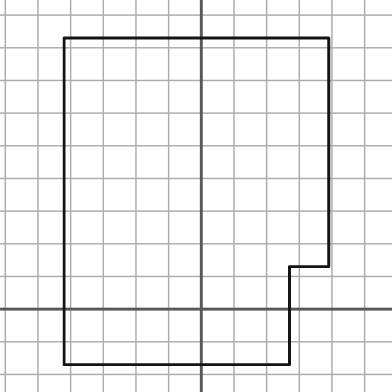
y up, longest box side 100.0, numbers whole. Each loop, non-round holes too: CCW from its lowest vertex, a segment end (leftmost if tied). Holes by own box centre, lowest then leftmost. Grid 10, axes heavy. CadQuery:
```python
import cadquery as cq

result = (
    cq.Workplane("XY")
    .moveTo(-42.0, -17.0)
    .lineTo(27.0, -17.0)
    .lineTo(27.0, 13.0)
    .lineTo(39.0, 13.0)
    .lineTo(39.0, 83.0)
    .lineTo(-42.0, 83.0)
    .close()
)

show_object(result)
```